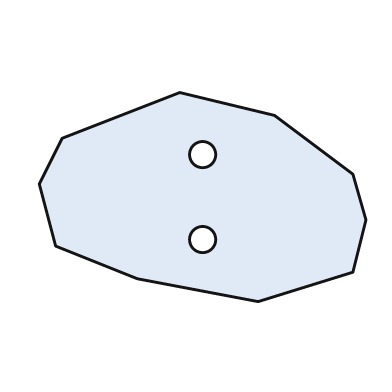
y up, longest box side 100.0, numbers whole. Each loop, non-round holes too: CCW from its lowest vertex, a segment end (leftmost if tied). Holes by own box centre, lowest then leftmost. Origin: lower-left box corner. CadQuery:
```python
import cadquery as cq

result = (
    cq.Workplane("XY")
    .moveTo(67.0, 0.0)
    .lineTo(96.0, 9.0)
    .lineTo(100.0, 25.0)
    .lineTo(96.0, 39.0)
    .lineTo(72.0, 57.0)
    .lineTo(43.0, 64.0)
    .lineTo(7.0, 50.0)
    .lineTo(0.0, 36.0)
    .lineTo(5.0, 17.0)
    .lineTo(30.0, 7.0)
    .close()
    .moveTo(50.0, 19.0)
    .circle(4.0)
    .moveTo(50.0, 45.0)
    .circle(4.0)
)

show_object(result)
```